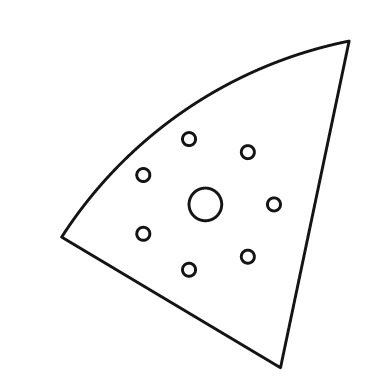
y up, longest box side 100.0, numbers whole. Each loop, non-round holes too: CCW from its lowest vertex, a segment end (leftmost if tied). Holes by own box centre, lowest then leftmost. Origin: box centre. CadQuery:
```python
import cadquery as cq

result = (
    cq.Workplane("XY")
    .moveTo(23.0, -50.0)
    .lineTo(44.0, 50.0)
    .threePointArc((-6.0, 29.0), (-44.0, -10.0))
    .close()
    .moveTo(-5.0, -20.0)
    .circle(2.0)
    .moveTo(13.0, -16.0)
    .circle(2.0)
    .moveTo(-19.0, -9.0)
    .circle(2.0)
    .moveTo(0.0, 0.0)
    .circle(5.0)
    .moveTo(21.0, 0.0)
    .circle(2.0)
    .moveTo(-19.0, 9.0)
    .circle(2.0)
    .moveTo(13.0, 16.0)
    .circle(2.0)
    .moveTo(-5.0, 20.0)
    .circle(2.0)
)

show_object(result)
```